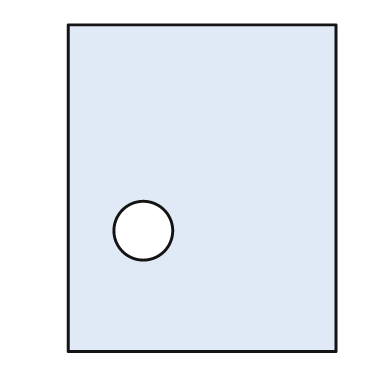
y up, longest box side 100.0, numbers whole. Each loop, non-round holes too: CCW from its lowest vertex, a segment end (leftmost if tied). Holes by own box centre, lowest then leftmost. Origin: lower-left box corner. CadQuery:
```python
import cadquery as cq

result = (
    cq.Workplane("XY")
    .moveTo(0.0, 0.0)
    .lineTo(82.0, 0.0)
    .lineTo(82.0, 100.0)
    .lineTo(0.0, 100.0)
    .close()
    .moveTo(23.0, 37.0)
    .circle(9.0)
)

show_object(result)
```